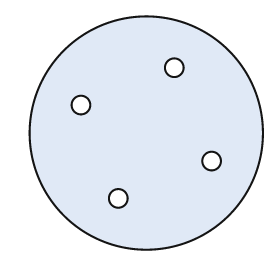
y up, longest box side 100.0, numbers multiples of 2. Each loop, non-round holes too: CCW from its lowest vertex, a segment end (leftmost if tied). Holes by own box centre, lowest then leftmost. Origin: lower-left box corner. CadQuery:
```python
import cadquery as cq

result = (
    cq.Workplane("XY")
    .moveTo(50.0, 50.0)
    .circle(50.0)
    .moveTo(38.0, 22.0)
    .circle(4.0)
    .moveTo(78.0, 38.0)
    .circle(4.0)
    .moveTo(22.0, 62.0)
    .circle(4.0)
    .moveTo(62.0, 78.0)
    .circle(4.0)
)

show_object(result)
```